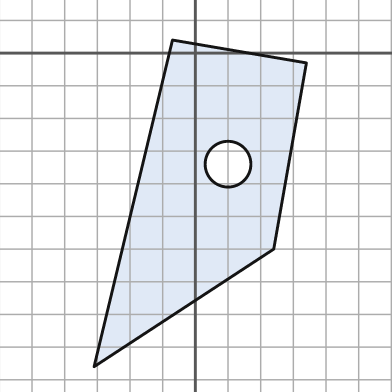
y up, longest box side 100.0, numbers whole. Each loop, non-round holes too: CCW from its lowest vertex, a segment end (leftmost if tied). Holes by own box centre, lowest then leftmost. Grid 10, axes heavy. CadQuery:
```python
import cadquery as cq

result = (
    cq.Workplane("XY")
    .moveTo(-31.0, -96.0)
    .lineTo(24.0, -60.0)
    .lineTo(34.0, -3.0)
    .lineTo(-7.0, 4.0)
    .close()
    .moveTo(10.0, -34.0)
    .circle(7.0)
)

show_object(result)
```